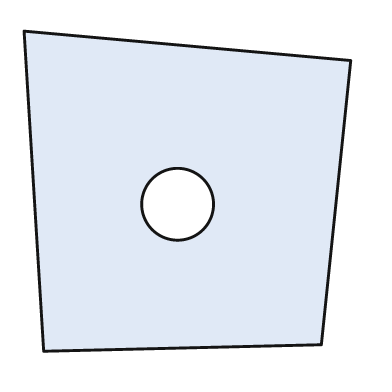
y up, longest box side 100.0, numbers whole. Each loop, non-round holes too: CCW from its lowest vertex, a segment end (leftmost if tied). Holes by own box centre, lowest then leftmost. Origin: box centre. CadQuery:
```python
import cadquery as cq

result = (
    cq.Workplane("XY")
    .moveTo(-44.0, -49.0)
    .lineTo(41.0, -47.0)
    .lineTo(50.0, 40.0)
    .lineTo(-50.0, 49.0)
    .close()
    .moveTo(-3.0, -4.0)
    .circle(11.0)
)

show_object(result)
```